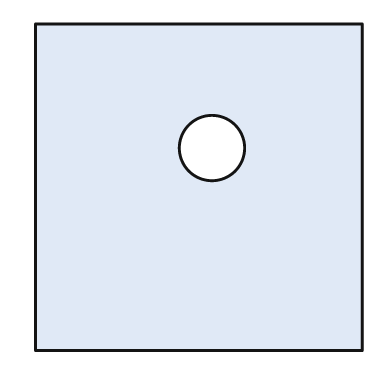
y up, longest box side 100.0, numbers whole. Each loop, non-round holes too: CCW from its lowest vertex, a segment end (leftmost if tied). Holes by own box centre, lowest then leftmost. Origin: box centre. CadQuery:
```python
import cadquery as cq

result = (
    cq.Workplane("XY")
    .moveTo(-50.0, -50.0)
    .lineTo(50.0, -50.0)
    .lineTo(50.0, 50.0)
    .lineTo(-50.0, 50.0)
    .close()
    .moveTo(4.0, 12.0)
    .circle(10.0)
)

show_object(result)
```